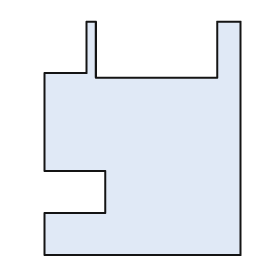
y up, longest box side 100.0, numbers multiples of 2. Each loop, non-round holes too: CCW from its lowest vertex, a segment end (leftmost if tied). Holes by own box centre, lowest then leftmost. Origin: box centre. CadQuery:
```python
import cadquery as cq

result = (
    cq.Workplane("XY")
    .moveTo(-42.0, -50.0)
    .lineTo(42.0, -50.0)
    .lineTo(42.0, 50.0)
    .lineTo(32.0, 50.0)
    .lineTo(32.0, 26.0)
    .lineTo(-20.0, 26.0)
    .lineTo(-20.0, 50.0)
    .lineTo(-24.0, 50.0)
    .lineTo(-24.0, 28.0)
    .lineTo(-42.0, 28.0)
    .lineTo(-42.0, -14.0)
    .lineTo(-16.0, -14.0)
    .lineTo(-16.0, -32.0)
    .lineTo(-42.0, -32.0)
    .close()
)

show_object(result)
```